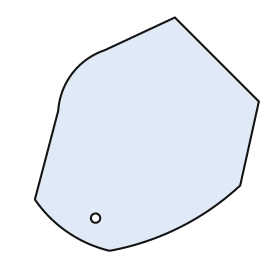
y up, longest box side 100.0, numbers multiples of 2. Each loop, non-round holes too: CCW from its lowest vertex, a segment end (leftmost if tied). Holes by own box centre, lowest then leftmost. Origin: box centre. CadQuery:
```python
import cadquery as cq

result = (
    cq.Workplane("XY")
    .moveTo(-16.0, -50.0)
    .threePointArc((14.0, -40.0), (40.0, -22.0))
    .lineTo(48.0, 14.0)
    .lineTo(12.0, 50.0)
    .lineTo(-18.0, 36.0)
    .threePointArc((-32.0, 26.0), (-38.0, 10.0))
    .lineTo(-48.0, -28.0)
    .threePointArc((-34.0, -42.0), (-16.0, -50.0))
    .close()
    .moveTo(-22.0, -36.0)
    .circle(2.0)
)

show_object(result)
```